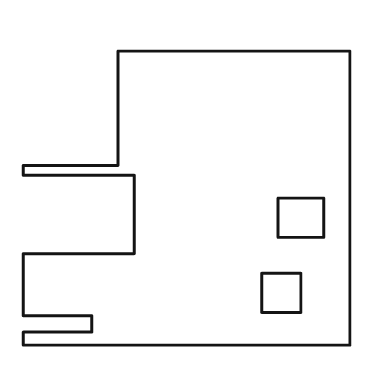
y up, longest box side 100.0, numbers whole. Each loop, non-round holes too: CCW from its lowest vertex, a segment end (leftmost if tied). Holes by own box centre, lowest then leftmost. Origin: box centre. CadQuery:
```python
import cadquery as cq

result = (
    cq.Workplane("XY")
    .moveTo(-50.0, -45.0)
    .lineTo(50.0, -45.0)
    .lineTo(50.0, 45.0)
    .lineTo(-21.0, 45.0)
    .lineTo(-21.0, 10.0)
    .lineTo(-50.0, 10.0)
    .lineTo(-50.0, 7.0)
    .lineTo(-16.0, 7.0)
    .lineTo(-16.0, -17.0)
    .lineTo(-50.0, -17.0)
    .lineTo(-50.0, -36.0)
    .lineTo(-29.0, -36.0)
    .lineTo(-29.0, -41.0)
    .lineTo(-50.0, -41.0)
    .close()
    .moveTo(23.0, -35.0)
    .lineTo(35.0, -35.0)
    .lineTo(35.0, -23.0)
    .lineTo(23.0, -23.0)
    .close()
    .moveTo(28.0, -12.0)
    .lineTo(42.0, -12.0)
    .lineTo(42.0, 0.0)
    .lineTo(28.0, 0.0)
    .close()
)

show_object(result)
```